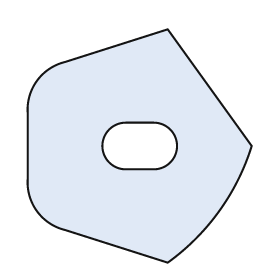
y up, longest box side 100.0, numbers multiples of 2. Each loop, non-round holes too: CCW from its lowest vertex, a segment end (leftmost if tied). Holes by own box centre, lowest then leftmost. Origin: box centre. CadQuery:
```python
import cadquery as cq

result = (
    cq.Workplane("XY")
    .moveTo(12.0, -50.0)
    .threePointArc((34.0, -28.0), (48.0, 0.0))
    .lineTo(12.0, 50.0)
    .lineTo(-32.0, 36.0)
    .threePointArc((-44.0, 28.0), (-48.0, 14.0))
    .lineTo(-48.0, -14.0)
    .threePointArc((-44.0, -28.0), (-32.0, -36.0))
    .close()
    .moveTo(-6.0, -10.0)
    .lineTo(6.0, -10.0)
    .threePointArc((16.0, 0.0), (6.0, 10.0))
    .lineTo(-6.0, 10.0)
    .threePointArc((-16.0, 0.0), (-6.0, -10.0))
    .close()
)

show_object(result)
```